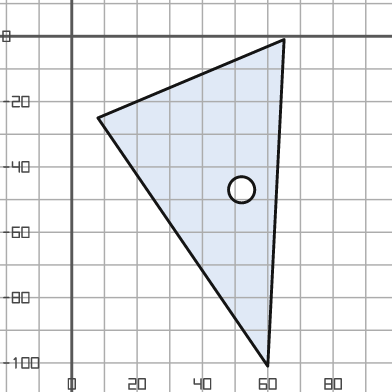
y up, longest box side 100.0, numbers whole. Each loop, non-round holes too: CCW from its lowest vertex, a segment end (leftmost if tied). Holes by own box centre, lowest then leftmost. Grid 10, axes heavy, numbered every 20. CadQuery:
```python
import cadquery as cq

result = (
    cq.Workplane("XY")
    .moveTo(60.0, -101.0)
    .lineTo(65.0, -1.0)
    .lineTo(8.0, -25.0)
    .close()
    .moveTo(52.0, -47.0)
    .circle(4.0)
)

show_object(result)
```